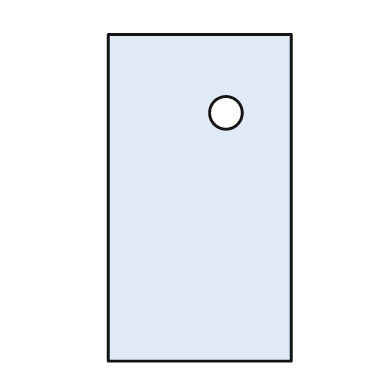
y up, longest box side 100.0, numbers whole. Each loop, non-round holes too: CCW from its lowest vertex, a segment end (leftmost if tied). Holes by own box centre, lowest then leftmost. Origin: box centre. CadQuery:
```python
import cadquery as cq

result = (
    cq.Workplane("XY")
    .moveTo(-28.0, -50.0)
    .lineTo(28.0, -50.0)
    .lineTo(28.0, 50.0)
    .lineTo(-28.0, 50.0)
    .close()
    .moveTo(8.0, 26.0)
    .circle(5.0)
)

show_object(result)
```